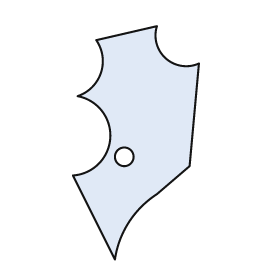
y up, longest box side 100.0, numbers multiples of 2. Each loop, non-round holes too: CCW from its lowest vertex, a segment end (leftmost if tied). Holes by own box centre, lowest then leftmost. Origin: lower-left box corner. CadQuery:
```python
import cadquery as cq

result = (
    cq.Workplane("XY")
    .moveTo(18.0, 0.0)
    .threePointArc((24.0, 16.0), (36.0, 28.0))
    .lineTo(50.0, 40.0)
    .lineTo(54.0, 84.0)
    .threePointArc((40.0, 86.0), (36.0, 100.0))
    .lineTo(10.0, 94.0)
    .threePointArc((12.0, 80.0), (2.0, 70.0))
    .threePointArc((16.0, 52.0), (0.0, 36.0))
    .close()
    .moveTo(22.0, 44.0)
    .circle(4.0)
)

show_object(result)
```